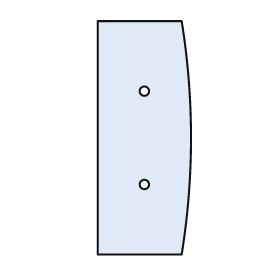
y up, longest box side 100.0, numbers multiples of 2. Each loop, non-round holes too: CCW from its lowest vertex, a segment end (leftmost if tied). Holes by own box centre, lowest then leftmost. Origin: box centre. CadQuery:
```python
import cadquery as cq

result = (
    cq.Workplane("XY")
    .moveTo(-20.0, -50.0)
    .lineTo(16.0, -50.0)
    .threePointArc((20.0, 0.0), (16.0, 50.0))
    .lineTo(-20.0, 50.0)
    .close()
    .moveTo(0.0, -20.0)
    .circle(2.0)
    .moveTo(0.0, 20.0)
    .circle(2.0)
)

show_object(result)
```